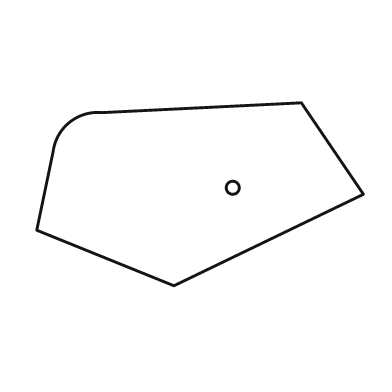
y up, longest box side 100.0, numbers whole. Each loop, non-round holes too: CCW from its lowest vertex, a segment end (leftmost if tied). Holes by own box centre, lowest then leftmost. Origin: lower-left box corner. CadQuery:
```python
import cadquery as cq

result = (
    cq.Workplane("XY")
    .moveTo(42.0, 0.0)
    .lineTo(100.0, 28.0)
    .lineTo(81.0, 56.0)
    .lineTo(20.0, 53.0)
    .threePointArc((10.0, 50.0), (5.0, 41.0))
    .lineTo(0.0, 17.0)
    .close()
    .moveTo(60.0, 30.0)
    .circle(2.0)
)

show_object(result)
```